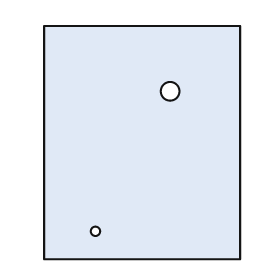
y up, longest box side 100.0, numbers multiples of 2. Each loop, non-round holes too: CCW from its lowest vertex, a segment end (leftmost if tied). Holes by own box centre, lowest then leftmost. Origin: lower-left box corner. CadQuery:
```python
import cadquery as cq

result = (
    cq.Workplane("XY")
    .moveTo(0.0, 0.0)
    .lineTo(84.0, 0.0)
    .lineTo(84.0, 100.0)
    .lineTo(0.0, 100.0)
    .close()
    .moveTo(22.0, 12.0)
    .circle(2.0)
    .moveTo(54.0, 72.0)
    .circle(4.0)
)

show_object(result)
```